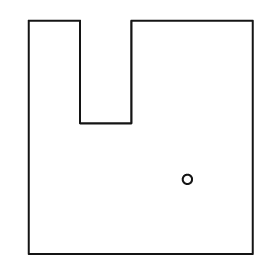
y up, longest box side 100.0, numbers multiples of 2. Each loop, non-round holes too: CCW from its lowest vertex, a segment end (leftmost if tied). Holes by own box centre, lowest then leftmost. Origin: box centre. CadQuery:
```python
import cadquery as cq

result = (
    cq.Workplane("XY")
    .moveTo(-48.0, -50.0)
    .lineTo(48.0, -50.0)
    .lineTo(48.0, 50.0)
    .lineTo(-4.0, 50.0)
    .lineTo(-4.0, 6.0)
    .lineTo(-26.0, 6.0)
    .lineTo(-26.0, 50.0)
    .lineTo(-48.0, 50.0)
    .close()
    .moveTo(20.0, -18.0)
    .circle(2.0)
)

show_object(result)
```